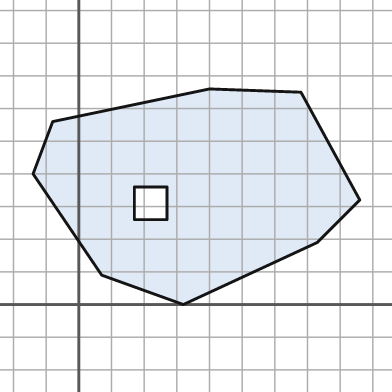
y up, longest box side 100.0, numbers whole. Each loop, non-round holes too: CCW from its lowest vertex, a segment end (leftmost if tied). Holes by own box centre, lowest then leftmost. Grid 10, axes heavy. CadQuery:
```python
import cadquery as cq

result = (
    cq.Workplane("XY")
    .moveTo(32.0, 0.0)
    .lineTo(73.0, 19.0)
    .lineTo(86.0, 32.0)
    .lineTo(68.0, 65.0)
    .lineTo(40.0, 66.0)
    .lineTo(-8.0, 56.0)
    .lineTo(-14.0, 40.0)
    .lineTo(7.0, 9.0)
    .close()
    .moveTo(17.0, 26.0)
    .lineTo(27.0, 26.0)
    .lineTo(27.0, 36.0)
    .lineTo(17.0, 36.0)
    .close()
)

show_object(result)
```